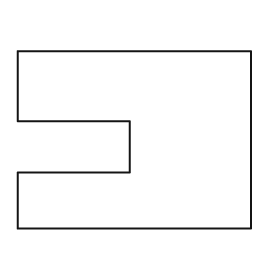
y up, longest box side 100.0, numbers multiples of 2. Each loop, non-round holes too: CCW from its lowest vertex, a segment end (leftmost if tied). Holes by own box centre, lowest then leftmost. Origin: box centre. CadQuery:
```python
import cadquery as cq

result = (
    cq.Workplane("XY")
    .moveTo(-50.0, -38.0)
    .lineTo(50.0, -38.0)
    .lineTo(50.0, 38.0)
    .lineTo(-50.0, 38.0)
    .lineTo(-50.0, 8.0)
    .lineTo(-2.0, 8.0)
    .lineTo(-2.0, -14.0)
    .lineTo(-50.0, -14.0)
    .close()
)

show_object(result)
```